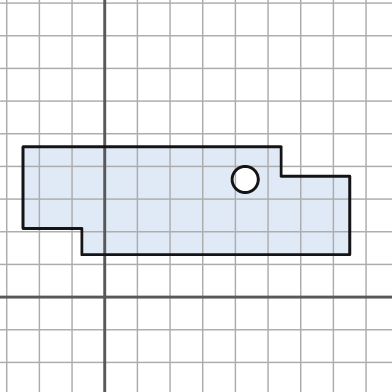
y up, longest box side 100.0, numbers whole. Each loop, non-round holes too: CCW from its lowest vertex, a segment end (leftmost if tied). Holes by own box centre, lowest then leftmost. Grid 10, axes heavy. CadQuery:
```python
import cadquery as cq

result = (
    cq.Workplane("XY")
    .moveTo(-7.0, 13.0)
    .lineTo(75.0, 13.0)
    .lineTo(75.0, 37.0)
    .lineTo(54.0, 37.0)
    .lineTo(54.0, 46.0)
    .lineTo(-25.0, 46.0)
    .lineTo(-25.0, 21.0)
    .lineTo(-7.0, 21.0)
    .close()
    .moveTo(43.0, 36.0)
    .circle(4.0)
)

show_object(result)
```